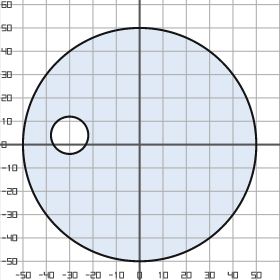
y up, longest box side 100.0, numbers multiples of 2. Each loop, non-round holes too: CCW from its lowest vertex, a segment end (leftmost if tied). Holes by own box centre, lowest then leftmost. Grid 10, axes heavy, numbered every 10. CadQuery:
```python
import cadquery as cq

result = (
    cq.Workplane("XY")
    .moveTo(0.0, 0.0)
    .circle(50.0)
    .moveTo(-30.0, 4.0)
    .circle(8.0)
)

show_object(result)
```